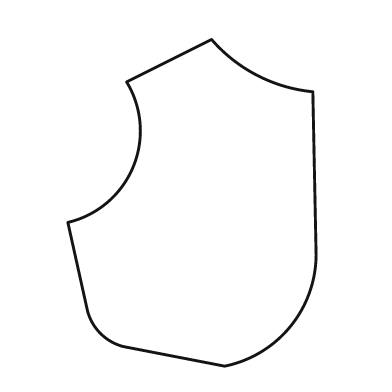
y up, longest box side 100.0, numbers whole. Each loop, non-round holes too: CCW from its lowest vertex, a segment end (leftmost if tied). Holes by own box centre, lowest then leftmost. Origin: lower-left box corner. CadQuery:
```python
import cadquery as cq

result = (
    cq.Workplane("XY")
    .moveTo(48.0, 0.0)
    .threePointArc((68.0, 12.0), (76.0, 34.0))
    .lineTo(75.0, 84.0)
    .threePointArc((58.0, 89.0), (44.0, 100.0))
    .lineTo(18.0, 87.0)
    .threePointArc((20.0, 61.0), (0.0, 44.0))
    .lineTo(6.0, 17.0)
    .threePointArc((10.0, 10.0), (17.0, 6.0))
    .close()
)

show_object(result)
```